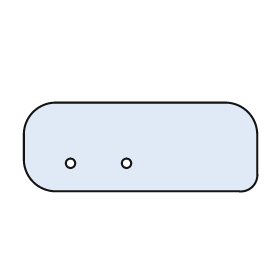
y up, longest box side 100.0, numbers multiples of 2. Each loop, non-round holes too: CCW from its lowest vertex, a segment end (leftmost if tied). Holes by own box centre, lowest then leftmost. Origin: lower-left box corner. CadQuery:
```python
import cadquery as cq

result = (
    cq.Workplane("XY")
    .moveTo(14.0, 0.0)
    .lineTo(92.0, 0.0)
    .threePointArc((98.0, 2.0), (100.0, 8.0))
    .lineTo(100.0, 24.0)
    .threePointArc((96.0, 34.0), (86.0, 38.0))
    .lineTo(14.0, 38.0)
    .threePointArc((4.0, 34.0), (0.0, 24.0))
    .lineTo(0.0, 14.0)
    .threePointArc((4.0, 4.0), (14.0, 0.0))
    .close()
    .moveTo(20.0, 12.0)
    .circle(2.0)
    .moveTo(44.0, 12.0)
    .circle(2.0)
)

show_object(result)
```